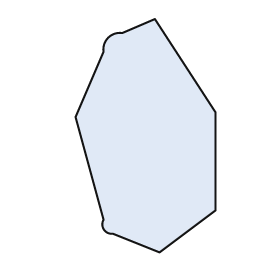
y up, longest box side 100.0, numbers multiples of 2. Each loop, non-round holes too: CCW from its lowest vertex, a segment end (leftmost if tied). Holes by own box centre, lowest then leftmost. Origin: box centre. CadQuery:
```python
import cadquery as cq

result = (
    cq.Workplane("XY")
    .moveTo(6.0, -50.0)
    .lineTo(30.0, -32.0)
    .lineTo(30.0, 10.0)
    .lineTo(4.0, 50.0)
    .lineTo(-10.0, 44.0)
    .threePointArc((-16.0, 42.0), (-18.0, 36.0))
    .lineTo(-30.0, 8.0)
    .lineTo(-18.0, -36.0)
    .threePointArc((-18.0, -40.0), (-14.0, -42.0))
    .close()
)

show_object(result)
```